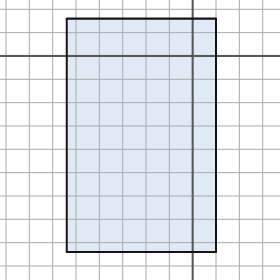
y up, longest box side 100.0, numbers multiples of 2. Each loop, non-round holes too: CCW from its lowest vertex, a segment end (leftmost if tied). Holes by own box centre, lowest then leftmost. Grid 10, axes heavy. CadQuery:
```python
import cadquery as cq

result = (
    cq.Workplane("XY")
    .moveTo(-54.0, -84.0)
    .lineTo(10.0, -84.0)
    .lineTo(10.0, 16.0)
    .lineTo(-54.0, 16.0)
    .close()
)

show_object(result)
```